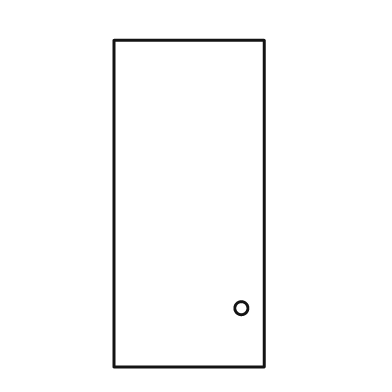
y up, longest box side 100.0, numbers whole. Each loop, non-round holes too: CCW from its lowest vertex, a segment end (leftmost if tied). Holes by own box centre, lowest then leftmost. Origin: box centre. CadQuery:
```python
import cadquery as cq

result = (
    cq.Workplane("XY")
    .moveTo(-23.0, -50.0)
    .lineTo(23.0, -50.0)
    .lineTo(23.0, 50.0)
    .lineTo(-23.0, 50.0)
    .close()
    .moveTo(16.0, -32.0)
    .circle(2.0)
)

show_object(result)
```